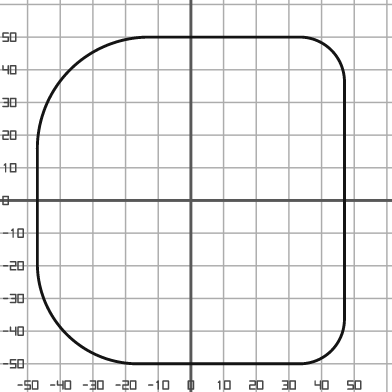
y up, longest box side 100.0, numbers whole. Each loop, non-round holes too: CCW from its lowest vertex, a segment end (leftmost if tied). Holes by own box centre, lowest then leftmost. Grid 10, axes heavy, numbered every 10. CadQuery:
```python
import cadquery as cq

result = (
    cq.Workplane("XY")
    .moveTo(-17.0, -50.0)
    .lineTo(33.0, -50.0)
    .threePointArc((43.0, -46.0), (47.0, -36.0))
    .lineTo(47.0, 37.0)
    .threePointArc((43.0, 46.0), (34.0, 50.0))
    .lineTo(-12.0, 50.0)
    .threePointArc((-37.0, 40.0), (-47.0, 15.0))
    .lineTo(-47.0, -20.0)
    .threePointArc((-38.0, -41.0), (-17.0, -50.0))
    .close()
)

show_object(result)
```